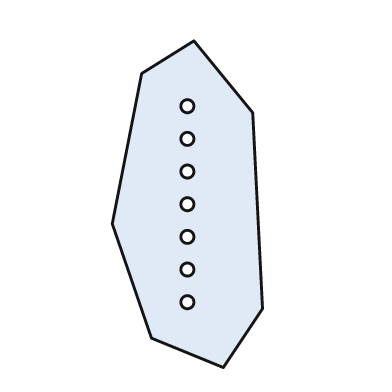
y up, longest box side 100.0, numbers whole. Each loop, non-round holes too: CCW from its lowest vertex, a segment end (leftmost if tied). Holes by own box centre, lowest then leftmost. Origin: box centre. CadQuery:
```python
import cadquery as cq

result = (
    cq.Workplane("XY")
    .moveTo(11.0, -50.0)
    .lineTo(23.0, -32.0)
    .lineTo(20.0, 28.0)
    .lineTo(2.0, 50.0)
    .lineTo(-14.0, 40.0)
    .lineTo(-23.0, -6.0)
    .lineTo(-11.0, -41.0)
    .close()
    .moveTo(0.0, -30.0)
    .circle(2.0)
    .moveTo(0.0, -20.0)
    .circle(2.0)
    .moveTo(0.0, -10.0)
    .circle(2.0)
    .moveTo(0.0, 0.0)
    .circle(2.0)
    .moveTo(0.0, 10.0)
    .circle(2.0)
    .moveTo(0.0, 20.0)
    .circle(2.0)
    .moveTo(0.0, 30.0)
    .circle(2.0)
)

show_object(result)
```